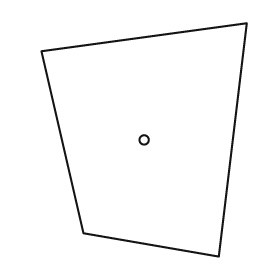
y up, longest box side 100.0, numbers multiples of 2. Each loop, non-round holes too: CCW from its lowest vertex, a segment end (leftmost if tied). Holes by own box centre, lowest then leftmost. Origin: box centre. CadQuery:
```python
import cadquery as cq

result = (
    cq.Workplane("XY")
    .moveTo(32.0, -50.0)
    .lineTo(44.0, 50.0)
    .lineTo(-44.0, 38.0)
    .lineTo(-26.0, -40.0)
    .close()
    .moveTo(0.0, 0.0)
    .circle(2.0)
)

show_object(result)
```